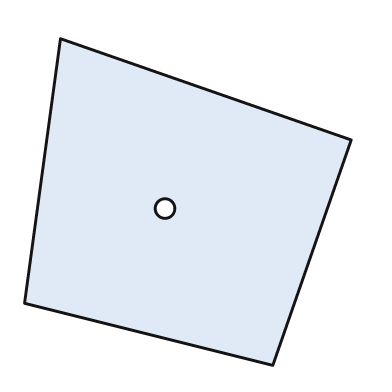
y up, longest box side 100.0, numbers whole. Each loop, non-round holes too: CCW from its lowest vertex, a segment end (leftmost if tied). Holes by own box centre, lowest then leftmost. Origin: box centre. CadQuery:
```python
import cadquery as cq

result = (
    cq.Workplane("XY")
    .moveTo(26.0, -50.0)
    .lineTo(50.0, 19.0)
    .lineTo(-39.0, 50.0)
    .lineTo(-50.0, -31.0)
    .close()
    .moveTo(-7.0, -2.0)
    .circle(3.0)
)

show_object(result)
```